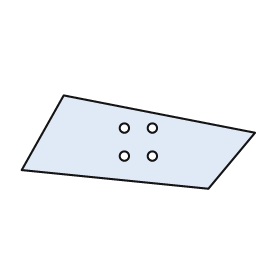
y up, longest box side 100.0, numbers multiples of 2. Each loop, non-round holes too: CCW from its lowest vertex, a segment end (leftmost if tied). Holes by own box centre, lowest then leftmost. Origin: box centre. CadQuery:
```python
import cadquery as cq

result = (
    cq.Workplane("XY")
    .moveTo(30.0, -20.0)
    .lineTo(50.0, 4.0)
    .lineTo(-32.0, 20.0)
    .lineTo(-50.0, -12.0)
    .close()
    .moveTo(-6.0, -6.0)
    .circle(2.0)
    .moveTo(6.0, -6.0)
    .circle(2.0)
    .moveTo(-6.0, 6.0)
    .circle(2.0)
    .moveTo(6.0, 6.0)
    .circle(2.0)
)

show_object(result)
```